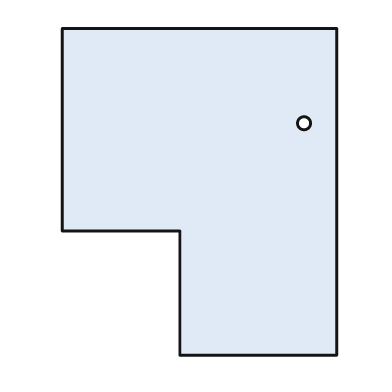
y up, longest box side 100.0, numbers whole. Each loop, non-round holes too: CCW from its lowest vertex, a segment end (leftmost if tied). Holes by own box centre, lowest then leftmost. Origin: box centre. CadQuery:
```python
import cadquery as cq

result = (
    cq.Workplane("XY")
    .moveTo(-6.0, -50.0)
    .lineTo(42.0, -50.0)
    .lineTo(42.0, 50.0)
    .lineTo(-42.0, 50.0)
    .lineTo(-42.0, -12.0)
    .lineTo(-6.0, -12.0)
    .close()
    .moveTo(32.0, 21.0)
    .circle(2.0)
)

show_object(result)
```